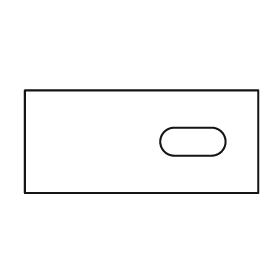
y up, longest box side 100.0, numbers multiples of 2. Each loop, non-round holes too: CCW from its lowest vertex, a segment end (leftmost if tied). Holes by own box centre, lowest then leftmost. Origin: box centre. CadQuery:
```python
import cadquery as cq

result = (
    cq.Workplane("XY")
    .moveTo(-50.0, -22.0)
    .lineTo(50.0, -22.0)
    .lineTo(50.0, 22.0)
    .lineTo(-50.0, 22.0)
    .close()
    .moveTo(14.0, -6.0)
    .lineTo(30.0, -6.0)
    .threePointArc((36.0, 0.0), (30.0, 6.0))
    .lineTo(14.0, 6.0)
    .threePointArc((8.0, 0.0), (14.0, -6.0))
    .close()
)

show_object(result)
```